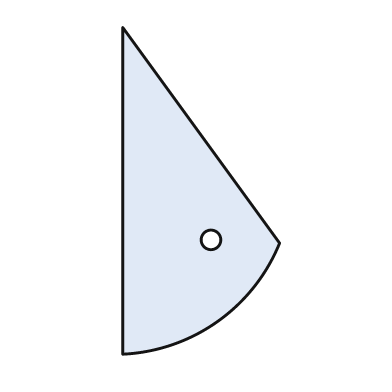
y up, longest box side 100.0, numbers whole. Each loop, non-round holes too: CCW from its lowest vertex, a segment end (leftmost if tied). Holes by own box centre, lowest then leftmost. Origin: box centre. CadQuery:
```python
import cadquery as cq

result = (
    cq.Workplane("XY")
    .moveTo(-24.0, -50.0)
    .threePointArc((5.0, -40.0), (24.0, -16.0))
    .lineTo(-24.0, 50.0)
    .close()
    .moveTo(3.0, -15.0)
    .circle(3.0)
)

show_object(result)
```